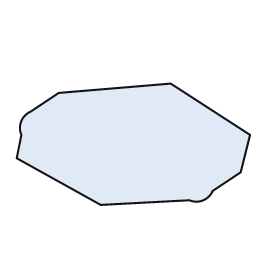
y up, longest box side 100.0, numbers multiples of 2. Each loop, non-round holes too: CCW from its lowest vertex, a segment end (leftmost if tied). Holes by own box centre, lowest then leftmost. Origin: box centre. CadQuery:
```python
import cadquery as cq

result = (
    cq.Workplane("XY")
    .moveTo(-14.0, -26.0)
    .lineTo(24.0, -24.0)
    .threePointArc((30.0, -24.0), (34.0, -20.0))
    .lineTo(46.0, -12.0)
    .lineTo(50.0, 4.0)
    .lineTo(16.0, 26.0)
    .lineTo(-32.0, 22.0)
    .lineTo(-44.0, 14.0)
    .threePointArc((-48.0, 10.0), (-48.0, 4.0))
    .lineTo(-50.0, -6.0)
    .close()
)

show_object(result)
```